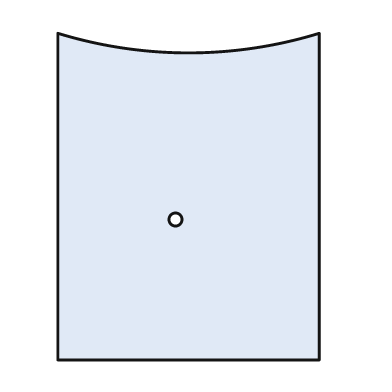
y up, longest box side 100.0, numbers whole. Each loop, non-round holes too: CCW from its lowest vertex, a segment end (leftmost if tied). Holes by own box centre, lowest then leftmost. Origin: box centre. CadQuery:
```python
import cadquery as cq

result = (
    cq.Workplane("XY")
    .moveTo(-40.0, -50.0)
    .lineTo(40.0, -50.0)
    .lineTo(40.0, 50.0)
    .threePointArc((0.0, 44.0), (-40.0, 50.0))
    .close()
    .moveTo(-4.0, -7.0)
    .circle(2.0)
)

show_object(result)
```